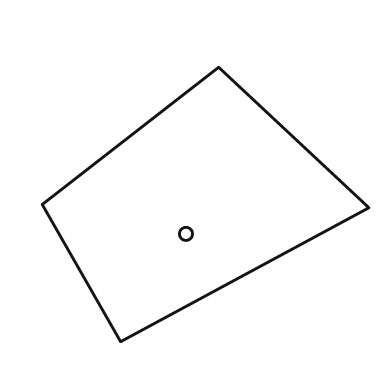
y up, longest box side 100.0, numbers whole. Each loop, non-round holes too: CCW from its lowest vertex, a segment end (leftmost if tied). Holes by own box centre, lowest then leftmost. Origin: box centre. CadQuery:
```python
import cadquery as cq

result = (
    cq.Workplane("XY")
    .moveTo(-26.0, -42.0)
    .lineTo(50.0, -1.0)
    .lineTo(4.0, 42.0)
    .lineTo(-50.0, 0.0)
    .close()
    .moveTo(-6.0, -9.0)
    .circle(2.0)
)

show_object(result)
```